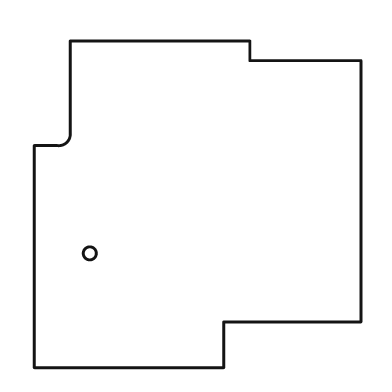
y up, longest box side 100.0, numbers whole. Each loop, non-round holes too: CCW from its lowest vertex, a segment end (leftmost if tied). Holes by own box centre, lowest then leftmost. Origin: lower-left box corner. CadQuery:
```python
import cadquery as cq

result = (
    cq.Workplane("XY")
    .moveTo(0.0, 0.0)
    .lineTo(58.0, 0.0)
    .lineTo(58.0, 14.0)
    .lineTo(100.0, 14.0)
    .lineTo(100.0, 94.0)
    .lineTo(66.0, 94.0)
    .lineTo(66.0, 100.0)
    .lineTo(11.0, 100.0)
    .lineTo(11.0, 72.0)
    .threePointArc((10.0, 69.0), (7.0, 68.0))
    .lineTo(0.0, 68.0)
    .close()
    .moveTo(17.0, 35.0)
    .circle(2.0)
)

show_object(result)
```